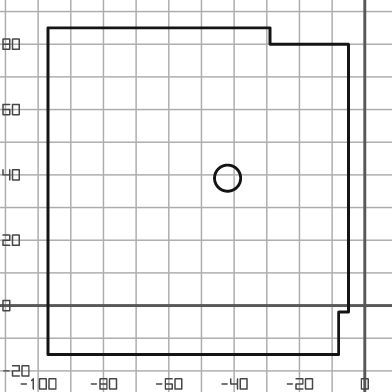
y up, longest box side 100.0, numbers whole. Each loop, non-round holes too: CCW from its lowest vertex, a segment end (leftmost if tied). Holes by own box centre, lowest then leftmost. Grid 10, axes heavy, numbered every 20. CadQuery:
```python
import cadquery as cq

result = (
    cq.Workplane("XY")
    .moveTo(-97.0, -15.0)
    .lineTo(-8.0, -15.0)
    .lineTo(-8.0, -2.0)
    .lineTo(-5.0, -2.0)
    .lineTo(-5.0, 80.0)
    .lineTo(-29.0, 80.0)
    .lineTo(-29.0, 85.0)
    .lineTo(-97.0, 85.0)
    .close()
    .moveTo(-42.0, 39.0)
    .circle(4.0)
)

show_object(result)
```